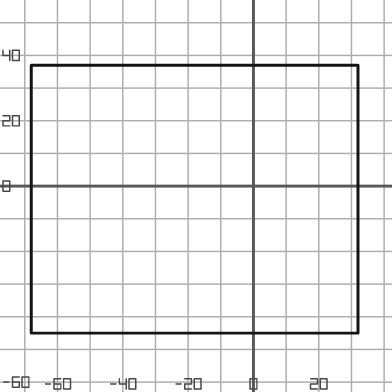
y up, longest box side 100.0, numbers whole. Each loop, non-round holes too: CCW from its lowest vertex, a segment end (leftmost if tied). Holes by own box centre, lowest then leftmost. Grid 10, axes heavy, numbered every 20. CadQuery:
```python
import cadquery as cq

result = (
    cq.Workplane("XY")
    .moveTo(-68.0, -45.0)
    .lineTo(32.0, -45.0)
    .lineTo(32.0, 37.0)
    .lineTo(-68.0, 37.0)
    .close()
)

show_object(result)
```